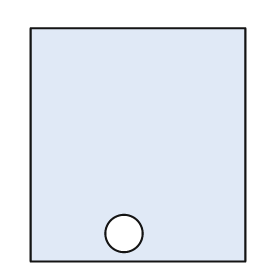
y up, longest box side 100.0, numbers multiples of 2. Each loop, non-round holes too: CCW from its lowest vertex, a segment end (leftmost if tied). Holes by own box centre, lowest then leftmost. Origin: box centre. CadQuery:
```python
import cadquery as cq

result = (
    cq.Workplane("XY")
    .moveTo(-46.0, -50.0)
    .lineTo(46.0, -50.0)
    .lineTo(46.0, 50.0)
    .lineTo(-46.0, 50.0)
    .close()
    .moveTo(-6.0, -38.0)
    .circle(8.0)
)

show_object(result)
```